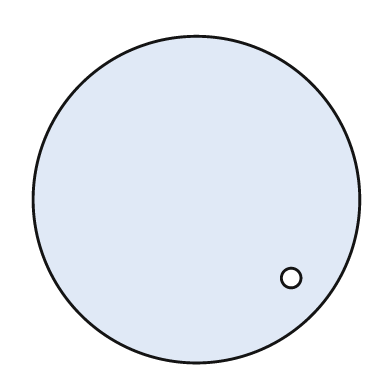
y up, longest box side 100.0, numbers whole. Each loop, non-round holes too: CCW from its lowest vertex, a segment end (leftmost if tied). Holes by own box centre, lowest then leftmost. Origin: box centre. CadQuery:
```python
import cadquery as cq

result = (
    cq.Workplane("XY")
    .moveTo(0.0, 0.0)
    .circle(50.0)
    .moveTo(29.0, -24.0)
    .circle(3.0)
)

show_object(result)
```